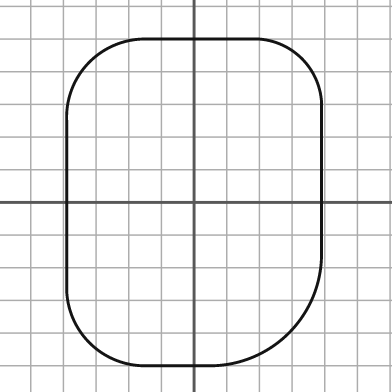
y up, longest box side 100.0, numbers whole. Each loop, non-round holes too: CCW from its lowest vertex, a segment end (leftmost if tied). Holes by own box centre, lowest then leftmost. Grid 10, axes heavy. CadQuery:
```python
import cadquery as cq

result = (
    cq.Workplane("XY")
    .moveTo(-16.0, -50.0)
    .lineTo(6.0, -50.0)
    .threePointArc((29.0, -40.0), (39.0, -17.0))
    .lineTo(39.0, 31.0)
    .threePointArc((33.0, 44.0), (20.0, 50.0))
    .lineTo(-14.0, 50.0)
    .threePointArc((-32.0, 43.0), (-39.0, 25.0))
    .lineTo(-39.0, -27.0)
    .threePointArc((-32.0, -43.0), (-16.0, -50.0))
    .close()
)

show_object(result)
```